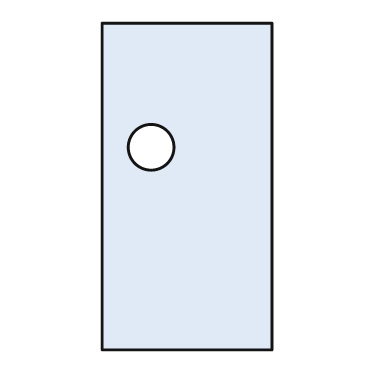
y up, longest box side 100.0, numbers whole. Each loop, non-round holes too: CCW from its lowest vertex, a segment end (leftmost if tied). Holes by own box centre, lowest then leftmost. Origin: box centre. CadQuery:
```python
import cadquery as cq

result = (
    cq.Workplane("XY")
    .moveTo(-26.0, -50.0)
    .lineTo(26.0, -50.0)
    .lineTo(26.0, 50.0)
    .lineTo(-26.0, 50.0)
    .close()
    .moveTo(-11.0, 12.0)
    .circle(7.0)
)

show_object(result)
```